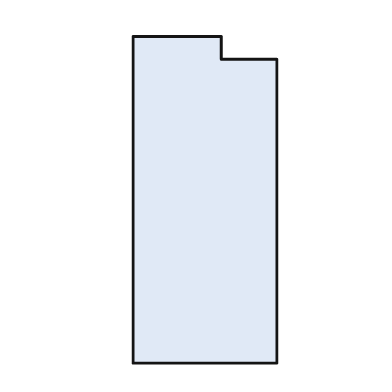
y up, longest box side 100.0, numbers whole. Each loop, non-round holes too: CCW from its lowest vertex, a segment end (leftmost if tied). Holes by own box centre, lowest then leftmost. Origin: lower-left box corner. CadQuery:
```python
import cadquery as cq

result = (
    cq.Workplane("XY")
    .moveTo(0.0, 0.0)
    .lineTo(44.0, 0.0)
    .lineTo(44.0, 93.0)
    .lineTo(27.0, 93.0)
    .lineTo(27.0, 100.0)
    .lineTo(0.0, 100.0)
    .close()
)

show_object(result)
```